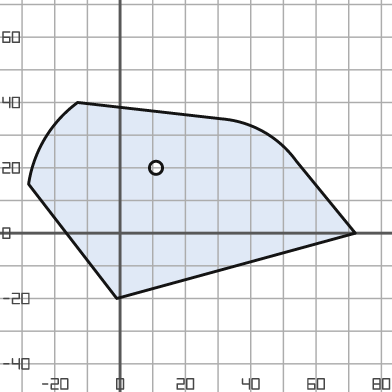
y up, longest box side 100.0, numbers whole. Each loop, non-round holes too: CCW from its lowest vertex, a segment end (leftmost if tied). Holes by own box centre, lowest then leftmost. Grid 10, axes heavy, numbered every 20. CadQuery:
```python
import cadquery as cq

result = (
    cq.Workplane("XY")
    .moveTo(-1.0, -20.0)
    .lineTo(72.0, 0.0)
    .lineTo(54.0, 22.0)
    .threePointArc((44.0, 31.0), (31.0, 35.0))
    .lineTo(-13.0, 40.0)
    .threePointArc((-23.0, 29.0), (-28.0, 15.0))
    .close()
    .moveTo(11.0, 20.0)
    .circle(2.0)
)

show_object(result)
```